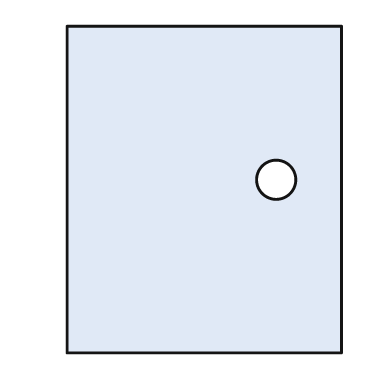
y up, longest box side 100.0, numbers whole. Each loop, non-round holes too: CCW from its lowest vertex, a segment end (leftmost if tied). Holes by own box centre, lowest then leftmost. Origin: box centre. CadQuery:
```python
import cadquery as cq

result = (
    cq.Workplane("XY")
    .moveTo(-42.0, -50.0)
    .lineTo(42.0, -50.0)
    .lineTo(42.0, 50.0)
    .lineTo(-42.0, 50.0)
    .close()
    .moveTo(22.0, 3.0)
    .circle(6.0)
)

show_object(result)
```